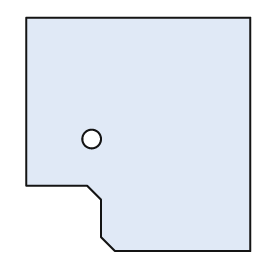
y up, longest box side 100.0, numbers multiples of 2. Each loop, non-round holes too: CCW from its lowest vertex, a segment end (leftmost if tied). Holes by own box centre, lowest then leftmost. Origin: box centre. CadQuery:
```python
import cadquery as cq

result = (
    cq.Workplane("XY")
    .moveTo(-10.0, -50.0)
    .lineTo(48.0, -50.0)
    .lineTo(48.0, 50.0)
    .lineTo(-48.0, 50.0)
    .lineTo(-48.0, -22.0)
    .lineTo(-22.0, -22.0)
    .lineTo(-16.0, -28.0)
    .lineTo(-16.0, -44.0)
    .close()
    .moveTo(-20.0, -2.0)
    .circle(4.0)
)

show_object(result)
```